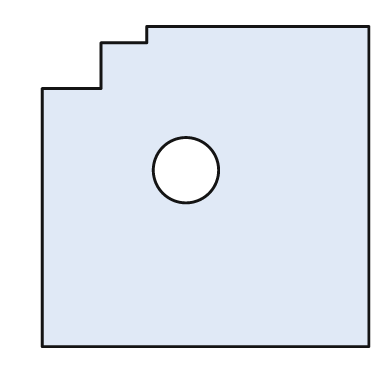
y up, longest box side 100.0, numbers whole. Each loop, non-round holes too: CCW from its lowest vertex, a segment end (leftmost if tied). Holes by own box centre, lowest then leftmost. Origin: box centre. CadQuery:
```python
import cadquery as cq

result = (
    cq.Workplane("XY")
    .moveTo(-50.0, -49.0)
    .lineTo(50.0, -49.0)
    .lineTo(50.0, 49.0)
    .lineTo(-18.0, 49.0)
    .lineTo(-18.0, 44.0)
    .lineTo(-32.0, 44.0)
    .lineTo(-32.0, 30.0)
    .lineTo(-50.0, 30.0)
    .close()
    .moveTo(-6.0, 5.0)
    .circle(10.0)
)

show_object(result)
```